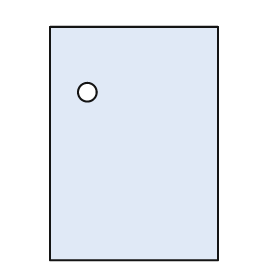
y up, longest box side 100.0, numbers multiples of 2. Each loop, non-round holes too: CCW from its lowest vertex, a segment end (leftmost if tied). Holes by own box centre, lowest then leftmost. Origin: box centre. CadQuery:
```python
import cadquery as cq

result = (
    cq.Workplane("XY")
    .moveTo(-36.0, -50.0)
    .lineTo(36.0, -50.0)
    .lineTo(36.0, 50.0)
    .lineTo(-36.0, 50.0)
    .close()
    .moveTo(-20.0, 22.0)
    .circle(4.0)
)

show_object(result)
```